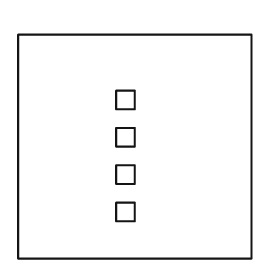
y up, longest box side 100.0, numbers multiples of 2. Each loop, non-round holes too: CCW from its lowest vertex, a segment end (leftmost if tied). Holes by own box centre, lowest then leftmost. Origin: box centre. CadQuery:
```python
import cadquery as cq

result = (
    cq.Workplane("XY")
    .moveTo(-50.0, -48.0)
    .lineTo(50.0, -48.0)
    .lineTo(50.0, 48.0)
    .lineTo(-50.0, 48.0)
    .close()
    .moveTo(-8.0, -32.0)
    .lineTo(0.0, -32.0)
    .lineTo(0.0, -24.0)
    .lineTo(-8.0, -24.0)
    .close()
    .moveTo(-8.0, -16.0)
    .lineTo(0.0, -16.0)
    .lineTo(0.0, -8.0)
    .lineTo(-8.0, -8.0)
    .close()
    .moveTo(-8.0, 0.0)
    .lineTo(0.0, 0.0)
    .lineTo(0.0, 8.0)
    .lineTo(-8.0, 8.0)
    .close()
    .moveTo(-8.0, 16.0)
    .lineTo(0.0, 16.0)
    .lineTo(0.0, 24.0)
    .lineTo(-8.0, 24.0)
    .close()
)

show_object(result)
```